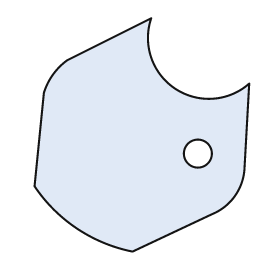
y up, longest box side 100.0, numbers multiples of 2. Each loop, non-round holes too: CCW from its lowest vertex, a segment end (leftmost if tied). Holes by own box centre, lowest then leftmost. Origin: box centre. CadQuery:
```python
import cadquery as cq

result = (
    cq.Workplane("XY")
    .moveTo(-4.0, -50.0)
    .lineTo(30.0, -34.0)
    .threePointArc((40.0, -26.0), (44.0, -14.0))
    .lineTo(46.0, 22.0)
    .threePointArc((14.0, 20.0), (4.0, 50.0))
    .lineTo(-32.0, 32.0)
    .threePointArc((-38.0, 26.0), (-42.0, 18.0))
    .lineTo(-46.0, -22.0)
    .threePointArc((-28.0, -40.0), (-4.0, -50.0))
    .close()
    .moveTo(24.0, -8.0)
    .circle(6.0)
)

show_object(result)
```